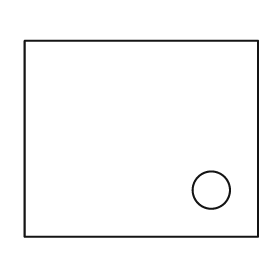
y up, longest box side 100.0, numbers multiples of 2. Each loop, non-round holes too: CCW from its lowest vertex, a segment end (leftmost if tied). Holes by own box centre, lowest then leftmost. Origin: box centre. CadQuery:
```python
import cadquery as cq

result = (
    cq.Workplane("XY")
    .moveTo(-50.0, -42.0)
    .lineTo(50.0, -42.0)
    .lineTo(50.0, 42.0)
    .lineTo(-50.0, 42.0)
    .close()
    .moveTo(30.0, -22.0)
    .circle(8.0)
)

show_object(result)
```